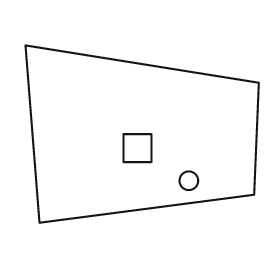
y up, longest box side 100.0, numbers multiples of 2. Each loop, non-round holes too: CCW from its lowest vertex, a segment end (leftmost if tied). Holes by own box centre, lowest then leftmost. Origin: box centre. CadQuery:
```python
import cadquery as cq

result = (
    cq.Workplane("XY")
    .moveTo(-44.0, -38.0)
    .lineTo(48.0, -26.0)
    .lineTo(50.0, 22.0)
    .lineTo(-50.0, 38.0)
    .close()
    .moveTo(20.0, -20.0)
    .circle(4.0)
    .moveTo(-8.0, -12.0)
    .lineTo(4.0, -12.0)
    .lineTo(4.0, 0.0)
    .lineTo(-8.0, 0.0)
    .close()
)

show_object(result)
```